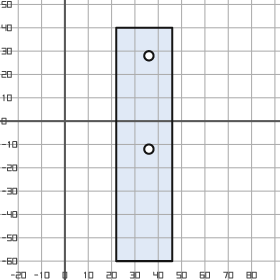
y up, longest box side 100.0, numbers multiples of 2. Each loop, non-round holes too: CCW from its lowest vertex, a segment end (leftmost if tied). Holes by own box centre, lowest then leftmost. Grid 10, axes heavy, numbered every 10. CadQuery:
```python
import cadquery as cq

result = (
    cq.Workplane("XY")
    .moveTo(22.0, -60.0)
    .lineTo(46.0, -60.0)
    .lineTo(46.0, 40.0)
    .lineTo(22.0, 40.0)
    .close()
    .moveTo(36.0, -12.0)
    .circle(2.0)
    .moveTo(36.0, 28.0)
    .circle(2.0)
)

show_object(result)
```